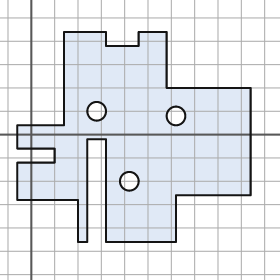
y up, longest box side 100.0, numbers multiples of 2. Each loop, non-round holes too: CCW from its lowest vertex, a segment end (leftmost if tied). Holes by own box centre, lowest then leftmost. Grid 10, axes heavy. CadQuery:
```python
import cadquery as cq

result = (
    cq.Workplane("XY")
    .moveTo(20.0, -46.0)
    .lineTo(24.0, -46.0)
    .lineTo(24.0, -2.0)
    .lineTo(32.0, -2.0)
    .lineTo(32.0, -46.0)
    .lineTo(62.0, -46.0)
    .lineTo(62.0, -26.0)
    .lineTo(94.0, -26.0)
    .lineTo(94.0, 20.0)
    .lineTo(58.0, 20.0)
    .lineTo(58.0, 44.0)
    .lineTo(46.0, 44.0)
    .lineTo(46.0, 38.0)
    .lineTo(32.0, 38.0)
    .lineTo(32.0, 44.0)
    .lineTo(14.0, 44.0)
    .lineTo(14.0, 4.0)
    .lineTo(-6.0, 4.0)
    .lineTo(-6.0, -6.0)
    .lineTo(10.0, -6.0)
    .lineTo(10.0, -12.0)
    .lineTo(-6.0, -12.0)
    .lineTo(-6.0, -28.0)
    .lineTo(20.0, -28.0)
    .close()
    .moveTo(42.0, -20.0)
    .circle(4.0)
    .moveTo(62.0, 8.0)
    .circle(4.0)
    .moveTo(28.0, 10.0)
    .circle(4.0)
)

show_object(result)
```